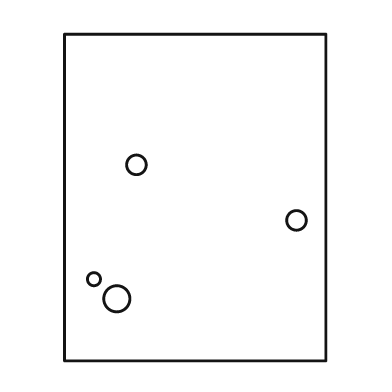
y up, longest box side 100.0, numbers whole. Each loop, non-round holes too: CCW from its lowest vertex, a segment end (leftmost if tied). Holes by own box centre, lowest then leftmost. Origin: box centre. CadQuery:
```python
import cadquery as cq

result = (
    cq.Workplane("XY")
    .moveTo(-40.0, -50.0)
    .lineTo(40.0, -50.0)
    .lineTo(40.0, 50.0)
    .lineTo(-40.0, 50.0)
    .close()
    .moveTo(-24.0, -31.0)
    .circle(4.0)
    .moveTo(-31.0, -25.0)
    .circle(2.0)
    .moveTo(31.0, -7.0)
    .circle(3.0)
    .moveTo(-18.0, 10.0)
    .circle(3.0)
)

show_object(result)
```